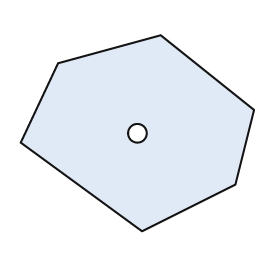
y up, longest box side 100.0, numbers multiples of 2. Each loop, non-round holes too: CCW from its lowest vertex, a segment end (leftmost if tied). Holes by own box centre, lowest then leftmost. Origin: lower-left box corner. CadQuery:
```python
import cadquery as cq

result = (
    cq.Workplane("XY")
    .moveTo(52.0, 0.0)
    .lineTo(92.0, 20.0)
    .lineTo(100.0, 52.0)
    .lineTo(60.0, 84.0)
    .lineTo(16.0, 72.0)
    .lineTo(0.0, 38.0)
    .close()
    .moveTo(50.0, 42.0)
    .circle(4.0)
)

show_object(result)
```